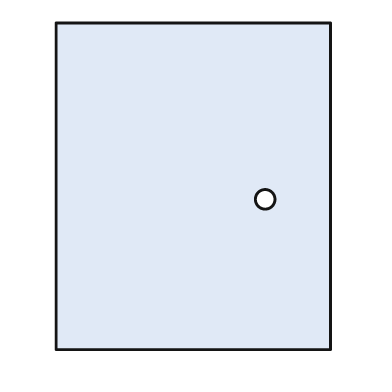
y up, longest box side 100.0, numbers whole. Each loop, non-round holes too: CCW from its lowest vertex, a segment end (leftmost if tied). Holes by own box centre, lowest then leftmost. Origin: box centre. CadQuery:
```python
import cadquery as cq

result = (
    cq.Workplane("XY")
    .moveTo(-42.0, -50.0)
    .lineTo(42.0, -50.0)
    .lineTo(42.0, 50.0)
    .lineTo(-42.0, 50.0)
    .close()
    .moveTo(22.0, -4.0)
    .circle(3.0)
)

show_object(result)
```